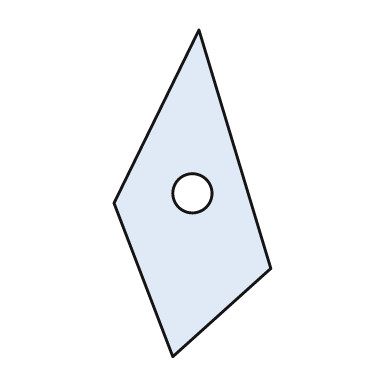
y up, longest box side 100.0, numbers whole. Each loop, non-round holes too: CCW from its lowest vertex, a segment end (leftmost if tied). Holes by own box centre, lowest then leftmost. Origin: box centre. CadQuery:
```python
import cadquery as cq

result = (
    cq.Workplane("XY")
    .moveTo(-6.0, -50.0)
    .lineTo(24.0, -23.0)
    .lineTo(2.0, 50.0)
    .lineTo(-24.0, -3.0)
    .close()
    .moveTo(0.0, 0.0)
    .circle(6.0)
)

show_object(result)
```